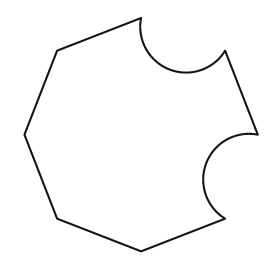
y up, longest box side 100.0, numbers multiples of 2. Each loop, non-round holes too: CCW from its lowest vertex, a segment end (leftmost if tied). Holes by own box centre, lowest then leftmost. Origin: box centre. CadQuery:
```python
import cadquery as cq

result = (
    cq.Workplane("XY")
    .moveTo(0.0, -50.0)
    .lineTo(36.0, -36.0)
    .threePointArc((28.0, -12.0), (50.0, 0.0))
    .lineTo(36.0, 36.0)
    .threePointArc((12.0, 28.0), (0.0, 50.0))
    .lineTo(-36.0, 36.0)
    .lineTo(-50.0, 0.0)
    .lineTo(-36.0, -36.0)
    .close()
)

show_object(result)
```